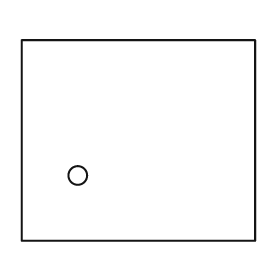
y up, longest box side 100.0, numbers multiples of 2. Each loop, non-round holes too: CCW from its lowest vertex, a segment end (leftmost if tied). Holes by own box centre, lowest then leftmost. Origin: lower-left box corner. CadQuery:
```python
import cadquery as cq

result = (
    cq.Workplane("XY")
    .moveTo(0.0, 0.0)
    .lineTo(100.0, 0.0)
    .lineTo(100.0, 86.0)
    .lineTo(0.0, 86.0)
    .close()
    .moveTo(24.0, 28.0)
    .circle(4.0)
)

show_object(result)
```